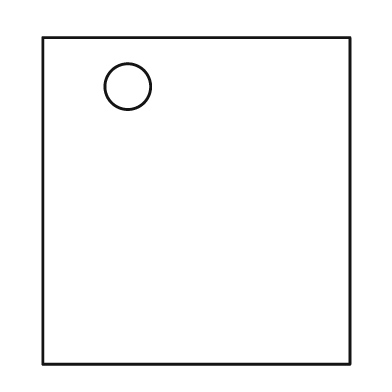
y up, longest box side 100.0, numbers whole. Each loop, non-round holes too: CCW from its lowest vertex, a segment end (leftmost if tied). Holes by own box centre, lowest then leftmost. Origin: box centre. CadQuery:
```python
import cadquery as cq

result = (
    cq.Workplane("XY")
    .moveTo(-47.0, -50.0)
    .lineTo(47.0, -50.0)
    .lineTo(47.0, 50.0)
    .lineTo(-47.0, 50.0)
    .close()
    .moveTo(-21.0, 35.0)
    .circle(7.0)
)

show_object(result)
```